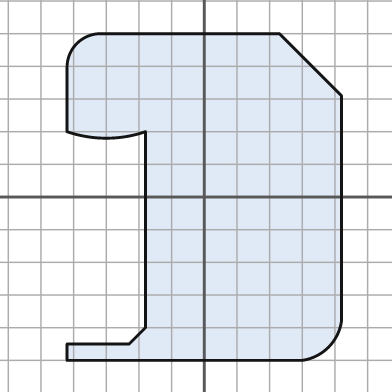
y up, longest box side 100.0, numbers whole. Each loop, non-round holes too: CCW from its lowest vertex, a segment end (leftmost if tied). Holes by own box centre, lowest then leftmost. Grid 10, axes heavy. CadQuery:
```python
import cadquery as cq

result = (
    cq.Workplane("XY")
    .moveTo(-42.0, -50.0)
    .lineTo(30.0, -50.0)
    .threePointArc((38.0, -46.0), (42.0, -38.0))
    .lineTo(42.0, 31.0)
    .lineTo(23.0, 50.0)
    .lineTo(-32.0, 50.0)
    .threePointArc((-39.0, 47.0), (-42.0, 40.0))
    .lineTo(-42.0, 20.0)
    .threePointArc((-30.0, 18.0), (-18.0, 20.0))
    .lineTo(-18.0, -40.0)
    .lineTo(-23.0, -45.0)
    .lineTo(-42.0, -45.0)
    .close()
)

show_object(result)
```